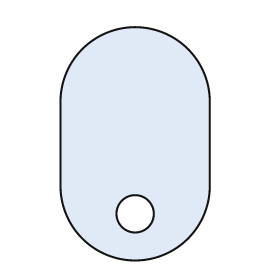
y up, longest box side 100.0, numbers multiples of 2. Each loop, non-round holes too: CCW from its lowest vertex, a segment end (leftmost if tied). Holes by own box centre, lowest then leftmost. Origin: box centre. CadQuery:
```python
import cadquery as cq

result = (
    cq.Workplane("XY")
    .moveTo(-32.0, -18.0)
    .threePointArc((0.0, -50.0), (32.0, -18.0))
    .lineTo(32.0, 18.0)
    .threePointArc((0.0, 50.0), (-32.0, 18.0))
    .close()
    .moveTo(0.0, -30.0)
    .circle(8.0)
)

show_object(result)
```